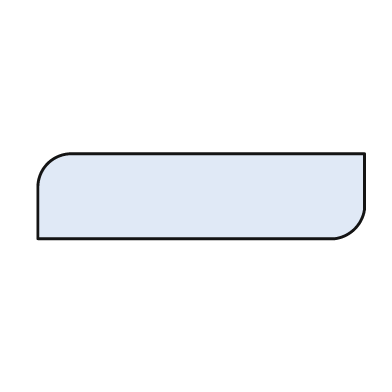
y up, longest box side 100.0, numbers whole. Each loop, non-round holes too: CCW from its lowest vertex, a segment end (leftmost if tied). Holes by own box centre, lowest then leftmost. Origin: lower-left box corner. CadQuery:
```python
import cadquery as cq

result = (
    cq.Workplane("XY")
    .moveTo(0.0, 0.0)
    .lineTo(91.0, 0.0)
    .threePointArc((97.0, 3.0), (100.0, 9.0))
    .lineTo(100.0, 26.0)
    .lineTo(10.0, 26.0)
    .threePointArc((3.0, 23.0), (0.0, 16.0))
    .close()
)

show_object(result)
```